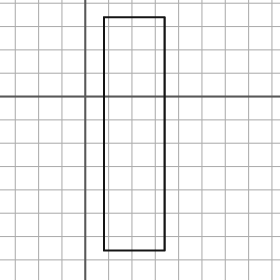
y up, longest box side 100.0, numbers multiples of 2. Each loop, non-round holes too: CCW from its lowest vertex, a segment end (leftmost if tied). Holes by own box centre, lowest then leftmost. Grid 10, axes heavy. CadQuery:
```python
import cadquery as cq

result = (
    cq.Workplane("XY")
    .moveTo(8.0, -66.0)
    .lineTo(34.0, -66.0)
    .lineTo(34.0, 34.0)
    .lineTo(8.0, 34.0)
    .close()
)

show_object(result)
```